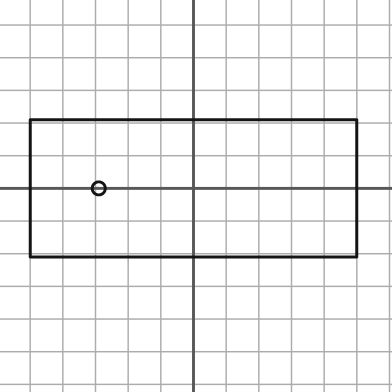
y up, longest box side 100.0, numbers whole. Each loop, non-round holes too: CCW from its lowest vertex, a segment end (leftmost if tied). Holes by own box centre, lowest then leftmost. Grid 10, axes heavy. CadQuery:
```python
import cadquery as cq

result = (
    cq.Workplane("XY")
    .moveTo(-50.0, -21.0)
    .lineTo(50.0, -21.0)
    .lineTo(50.0, 21.0)
    .lineTo(-50.0, 21.0)
    .close()
    .moveTo(-29.0, 0.0)
    .circle(2.0)
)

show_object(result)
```